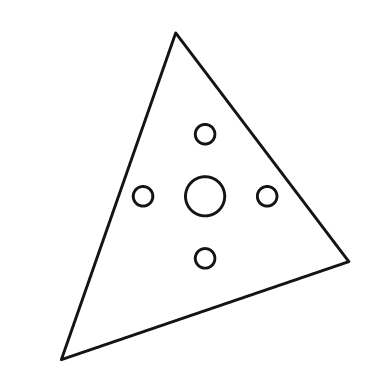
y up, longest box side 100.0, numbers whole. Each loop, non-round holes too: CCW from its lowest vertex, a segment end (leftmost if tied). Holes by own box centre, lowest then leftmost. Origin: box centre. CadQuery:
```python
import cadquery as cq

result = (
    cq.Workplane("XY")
    .moveTo(-44.0, -50.0)
    .lineTo(44.0, -20.0)
    .lineTo(-9.0, 50.0)
    .close()
    .moveTo(0.0, -19.0)
    .circle(3.0)
    .moveTo(-19.0, 0.0)
    .circle(3.0)
    .moveTo(0.0, 0.0)
    .circle(6.0)
    .moveTo(19.0, 0.0)
    .circle(3.0)
    .moveTo(0.0, 19.0)
    .circle(3.0)
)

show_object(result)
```